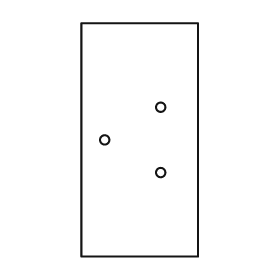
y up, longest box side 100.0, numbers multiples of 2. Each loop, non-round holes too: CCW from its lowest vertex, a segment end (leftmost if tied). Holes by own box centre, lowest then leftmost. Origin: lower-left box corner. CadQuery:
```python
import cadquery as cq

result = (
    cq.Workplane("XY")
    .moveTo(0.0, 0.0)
    .lineTo(50.0, 0.0)
    .lineTo(50.0, 100.0)
    .lineTo(0.0, 100.0)
    .close()
    .moveTo(34.0, 36.0)
    .circle(2.0)
    .moveTo(10.0, 50.0)
    .circle(2.0)
    .moveTo(34.0, 64.0)
    .circle(2.0)
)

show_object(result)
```